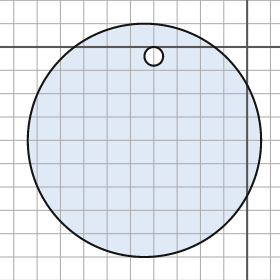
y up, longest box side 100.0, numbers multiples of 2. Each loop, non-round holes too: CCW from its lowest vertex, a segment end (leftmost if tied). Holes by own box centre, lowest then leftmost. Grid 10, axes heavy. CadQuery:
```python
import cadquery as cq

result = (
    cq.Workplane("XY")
    .moveTo(-44.0, -40.0)
    .circle(50.0)
    .moveTo(-40.0, -4.0)
    .circle(4.0)
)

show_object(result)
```